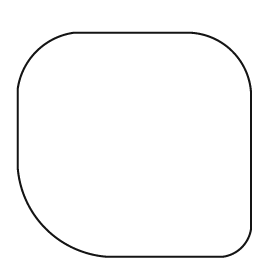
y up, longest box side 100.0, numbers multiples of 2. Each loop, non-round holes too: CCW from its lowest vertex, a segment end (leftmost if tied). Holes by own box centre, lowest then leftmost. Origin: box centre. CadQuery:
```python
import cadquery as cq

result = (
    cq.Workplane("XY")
    .moveTo(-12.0, -48.0)
    .lineTo(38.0, -48.0)
    .threePointArc((46.0, -44.0), (50.0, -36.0))
    .lineTo(50.0, 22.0)
    .threePointArc((42.0, 40.0), (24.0, 48.0))
    .lineTo(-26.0, 48.0)
    .threePointArc((-42.0, 40.0), (-50.0, 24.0))
    .lineTo(-50.0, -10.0)
    .threePointArc((-38.0, -36.0), (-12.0, -48.0))
    .close()
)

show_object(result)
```